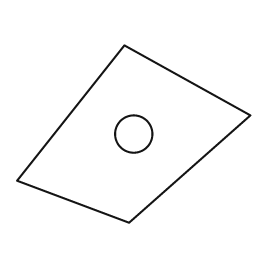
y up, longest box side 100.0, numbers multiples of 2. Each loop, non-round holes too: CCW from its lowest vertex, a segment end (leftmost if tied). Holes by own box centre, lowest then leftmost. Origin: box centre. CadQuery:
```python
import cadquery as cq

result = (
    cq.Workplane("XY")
    .moveTo(-2.0, -38.0)
    .lineTo(50.0, 8.0)
    .lineTo(-4.0, 38.0)
    .lineTo(-50.0, -20.0)
    .close()
    .moveTo(0.0, 0.0)
    .circle(8.0)
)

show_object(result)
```